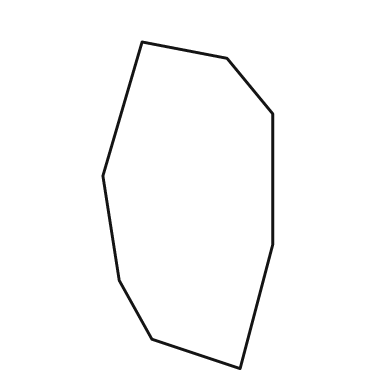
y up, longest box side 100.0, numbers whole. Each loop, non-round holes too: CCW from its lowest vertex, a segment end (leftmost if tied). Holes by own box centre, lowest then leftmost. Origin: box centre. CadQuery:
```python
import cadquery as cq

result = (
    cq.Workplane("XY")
    .moveTo(16.0, -50.0)
    .lineTo(26.0, -12.0)
    .lineTo(26.0, 28.0)
    .lineTo(12.0, 45.0)
    .lineTo(-14.0, 50.0)
    .lineTo(-26.0, 9.0)
    .lineTo(-21.0, -23.0)
    .lineTo(-11.0, -41.0)
    .close()
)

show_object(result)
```